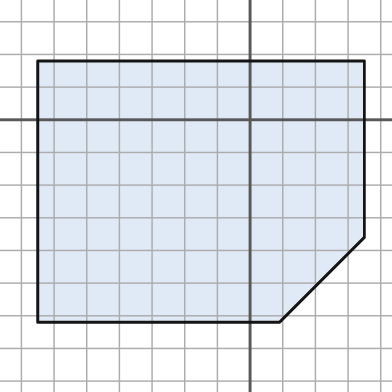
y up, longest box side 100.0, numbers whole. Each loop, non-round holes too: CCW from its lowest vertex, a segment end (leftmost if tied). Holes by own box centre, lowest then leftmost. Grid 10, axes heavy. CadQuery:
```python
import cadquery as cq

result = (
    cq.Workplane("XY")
    .moveTo(-65.0, -62.0)
    .lineTo(9.0, -62.0)
    .lineTo(35.0, -36.0)
    .lineTo(35.0, 18.0)
    .lineTo(-65.0, 18.0)
    .close()
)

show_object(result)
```